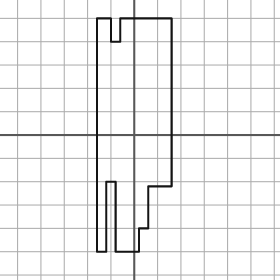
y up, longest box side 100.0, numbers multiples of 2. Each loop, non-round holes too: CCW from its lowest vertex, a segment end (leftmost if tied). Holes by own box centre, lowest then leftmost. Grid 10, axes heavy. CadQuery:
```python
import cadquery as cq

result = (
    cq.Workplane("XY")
    .moveTo(-16.0, -50.0)
    .lineTo(-12.0, -50.0)
    .lineTo(-12.0, -20.0)
    .lineTo(-8.0, -20.0)
    .lineTo(-8.0, -50.0)
    .lineTo(2.0, -50.0)
    .lineTo(2.0, -40.0)
    .lineTo(6.0, -40.0)
    .lineTo(6.0, -22.0)
    .lineTo(16.0, -22.0)
    .lineTo(16.0, 50.0)
    .lineTo(-6.0, 50.0)
    .lineTo(-6.0, 40.0)
    .lineTo(-10.0, 40.0)
    .lineTo(-10.0, 50.0)
    .lineTo(-16.0, 50.0)
    .close()
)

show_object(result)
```